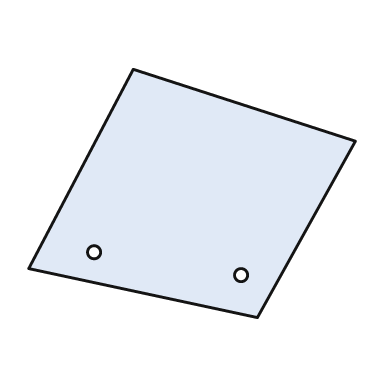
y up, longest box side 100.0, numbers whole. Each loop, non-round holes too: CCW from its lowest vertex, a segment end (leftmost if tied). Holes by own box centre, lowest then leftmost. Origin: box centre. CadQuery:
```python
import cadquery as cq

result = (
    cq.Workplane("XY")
    .moveTo(20.0, -38.0)
    .lineTo(50.0, 16.0)
    .lineTo(-18.0, 38.0)
    .lineTo(-50.0, -23.0)
    .close()
    .moveTo(15.0, -25.0)
    .circle(2.0)
    .moveTo(-30.0, -18.0)
    .circle(2.0)
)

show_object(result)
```